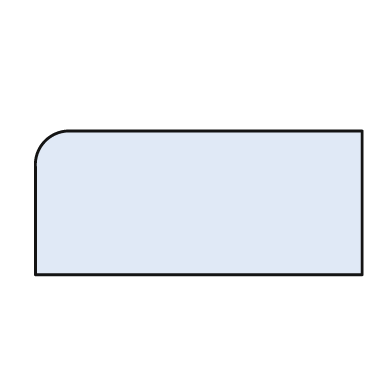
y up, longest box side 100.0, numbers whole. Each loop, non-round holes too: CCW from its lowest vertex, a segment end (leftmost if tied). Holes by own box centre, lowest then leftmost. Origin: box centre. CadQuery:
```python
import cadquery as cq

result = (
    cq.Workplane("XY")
    .moveTo(-50.0, -22.0)
    .lineTo(50.0, -22.0)
    .lineTo(50.0, 22.0)
    .lineTo(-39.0, 22.0)
    .threePointArc((-47.0, 19.0), (-50.0, 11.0))
    .close()
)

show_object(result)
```